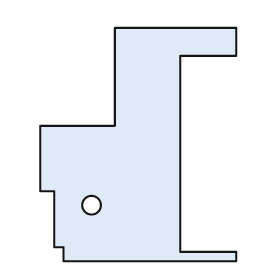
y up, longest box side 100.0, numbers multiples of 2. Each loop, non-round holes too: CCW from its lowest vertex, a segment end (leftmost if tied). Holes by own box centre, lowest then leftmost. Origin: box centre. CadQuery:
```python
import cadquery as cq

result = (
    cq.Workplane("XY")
    .moveTo(-32.0, -50.0)
    .lineTo(42.0, -50.0)
    .lineTo(42.0, -46.0)
    .lineTo(18.0, -46.0)
    .lineTo(18.0, 38.0)
    .lineTo(42.0, 38.0)
    .lineTo(42.0, 50.0)
    .lineTo(-10.0, 50.0)
    .lineTo(-10.0, 8.0)
    .lineTo(-42.0, 8.0)
    .lineTo(-42.0, -20.0)
    .lineTo(-36.0, -20.0)
    .lineTo(-36.0, -44.0)
    .lineTo(-32.0, -44.0)
    .close()
    .moveTo(-20.0, -26.0)
    .circle(4.0)
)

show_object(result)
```